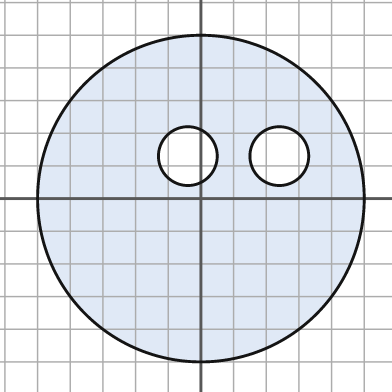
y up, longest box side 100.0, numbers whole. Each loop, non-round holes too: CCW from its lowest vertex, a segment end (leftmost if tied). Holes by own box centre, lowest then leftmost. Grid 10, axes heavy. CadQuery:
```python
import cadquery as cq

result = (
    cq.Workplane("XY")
    .moveTo(0.0, 0.0)
    .circle(50.0)
    .moveTo(-4.0, 13.0)
    .circle(9.0)
    .moveTo(24.0, 13.0)
    .circle(9.0)
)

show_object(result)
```